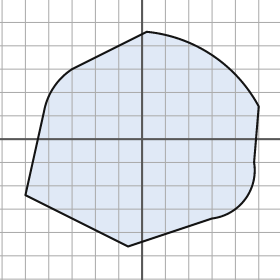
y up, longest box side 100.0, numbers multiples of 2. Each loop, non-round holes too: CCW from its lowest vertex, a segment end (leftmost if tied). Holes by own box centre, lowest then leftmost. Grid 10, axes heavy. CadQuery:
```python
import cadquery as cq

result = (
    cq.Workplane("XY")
    .moveTo(-6.0, -46.0)
    .lineTo(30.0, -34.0)
    .threePointArc((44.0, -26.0), (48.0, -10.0))
    .lineTo(50.0, 14.0)
    .threePointArc((30.0, 36.0), (2.0, 46.0))
    .lineTo(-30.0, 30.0)
    .threePointArc((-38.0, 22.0), (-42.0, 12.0))
    .lineTo(-50.0, -24.0)
    .close()
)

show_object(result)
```